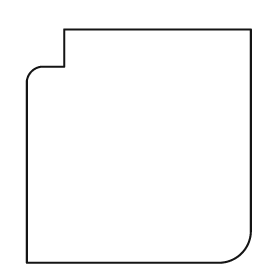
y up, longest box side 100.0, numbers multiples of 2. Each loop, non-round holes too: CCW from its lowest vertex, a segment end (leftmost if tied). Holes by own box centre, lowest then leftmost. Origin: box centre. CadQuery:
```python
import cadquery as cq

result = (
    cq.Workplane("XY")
    .moveTo(-48.0, -50.0)
    .lineTo(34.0, -50.0)
    .threePointArc((44.0, -46.0), (48.0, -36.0))
    .lineTo(48.0, 50.0)
    .lineTo(-32.0, 50.0)
    .lineTo(-32.0, 34.0)
    .lineTo(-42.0, 34.0)
    .threePointArc((-46.0, 32.0), (-48.0, 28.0))
    .close()
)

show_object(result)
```